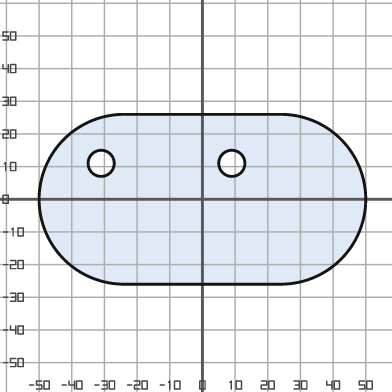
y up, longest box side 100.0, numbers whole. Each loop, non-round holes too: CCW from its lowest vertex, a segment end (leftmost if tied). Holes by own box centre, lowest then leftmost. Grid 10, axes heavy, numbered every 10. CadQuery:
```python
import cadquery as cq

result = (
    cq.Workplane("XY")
    .moveTo(-24.0, -26.0)
    .lineTo(24.0, -26.0)
    .threePointArc((50.0, 0.0), (24.0, 26.0))
    .lineTo(-24.0, 26.0)
    .threePointArc((-50.0, 0.0), (-24.0, -26.0))
    .close()
    .moveTo(-31.0, 11.0)
    .circle(4.0)
    .moveTo(9.0, 11.0)
    .circle(4.0)
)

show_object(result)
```